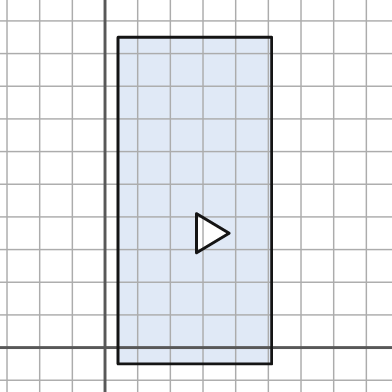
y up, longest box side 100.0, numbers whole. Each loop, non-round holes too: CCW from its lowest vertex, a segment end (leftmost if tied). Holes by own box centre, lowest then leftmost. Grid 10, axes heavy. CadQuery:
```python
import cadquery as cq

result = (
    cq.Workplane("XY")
    .moveTo(4.0, -5.0)
    .lineTo(51.0, -5.0)
    .lineTo(51.0, 95.0)
    .lineTo(4.0, 95.0)
    .close()
    .moveTo(28.0, 29.0)
    .lineTo(38.0, 35.0)
    .lineTo(28.0, 41.0)
    .close()
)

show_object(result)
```